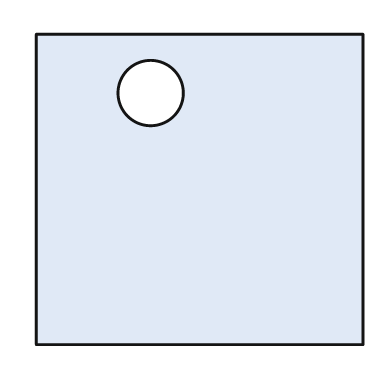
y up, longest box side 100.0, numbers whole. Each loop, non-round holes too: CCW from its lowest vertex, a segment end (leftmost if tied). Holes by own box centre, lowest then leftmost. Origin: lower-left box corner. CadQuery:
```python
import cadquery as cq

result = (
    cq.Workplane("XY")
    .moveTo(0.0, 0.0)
    .lineTo(100.0, 0.0)
    .lineTo(100.0, 95.0)
    .lineTo(0.0, 95.0)
    .close()
    .moveTo(35.0, 77.0)
    .circle(10.0)
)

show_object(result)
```